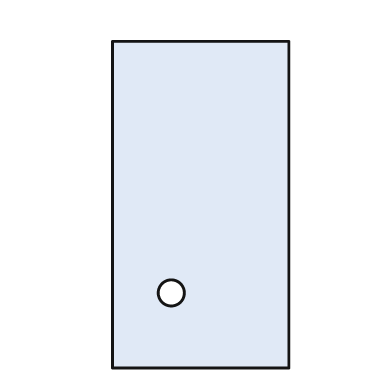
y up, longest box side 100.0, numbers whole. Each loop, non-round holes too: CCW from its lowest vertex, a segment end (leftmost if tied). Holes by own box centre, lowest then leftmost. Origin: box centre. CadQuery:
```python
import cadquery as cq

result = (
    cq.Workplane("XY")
    .moveTo(-27.0, -50.0)
    .lineTo(27.0, -50.0)
    .lineTo(27.0, 50.0)
    .lineTo(-27.0, 50.0)
    .close()
    .moveTo(-9.0, -27.0)
    .circle(4.0)
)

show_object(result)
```